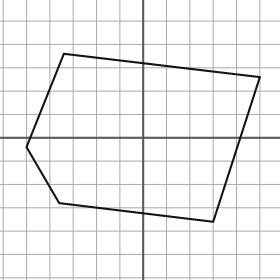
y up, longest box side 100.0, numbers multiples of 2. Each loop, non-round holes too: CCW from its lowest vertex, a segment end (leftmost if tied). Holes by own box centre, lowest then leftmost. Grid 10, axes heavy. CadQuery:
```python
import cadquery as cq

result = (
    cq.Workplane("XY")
    .moveTo(30.0, -36.0)
    .lineTo(50.0, 26.0)
    .lineTo(-34.0, 36.0)
    .lineTo(-50.0, -4.0)
    .lineTo(-36.0, -28.0)
    .close()
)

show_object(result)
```